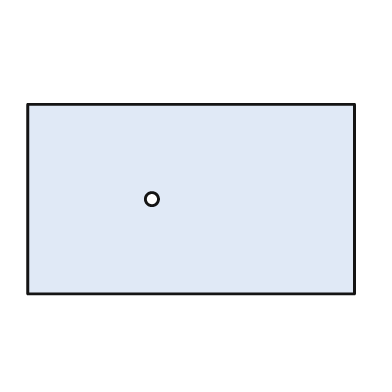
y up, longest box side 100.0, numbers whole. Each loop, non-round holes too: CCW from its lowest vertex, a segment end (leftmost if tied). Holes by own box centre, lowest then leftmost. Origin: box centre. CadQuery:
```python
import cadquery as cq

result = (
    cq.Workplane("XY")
    .moveTo(-50.0, -29.0)
    .lineTo(50.0, -29.0)
    .lineTo(50.0, 29.0)
    .lineTo(-50.0, 29.0)
    .close()
    .moveTo(-12.0, 0.0)
    .circle(2.0)
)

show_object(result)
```